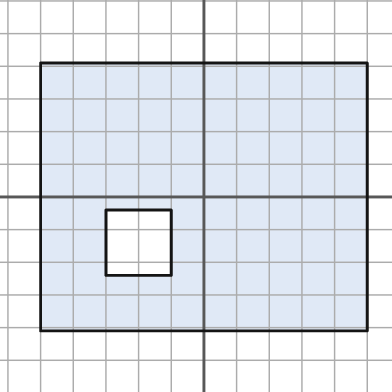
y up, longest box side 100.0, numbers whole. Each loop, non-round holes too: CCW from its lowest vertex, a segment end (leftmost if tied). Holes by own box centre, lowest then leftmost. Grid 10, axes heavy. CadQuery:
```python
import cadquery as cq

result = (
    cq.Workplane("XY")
    .moveTo(-50.0, -41.0)
    .lineTo(50.0, -41.0)
    .lineTo(50.0, 41.0)
    .lineTo(-50.0, 41.0)
    .close()
    .moveTo(-30.0, -24.0)
    .lineTo(-10.0, -24.0)
    .lineTo(-10.0, -4.0)
    .lineTo(-30.0, -4.0)
    .close()
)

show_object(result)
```